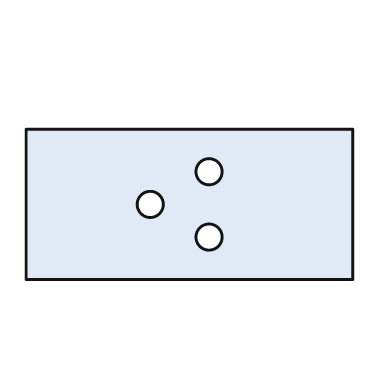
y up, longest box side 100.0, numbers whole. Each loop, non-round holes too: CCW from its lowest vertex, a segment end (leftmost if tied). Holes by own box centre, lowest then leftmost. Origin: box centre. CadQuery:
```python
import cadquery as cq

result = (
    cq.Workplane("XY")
    .moveTo(-50.0, -23.0)
    .lineTo(50.0, -23.0)
    .lineTo(50.0, 23.0)
    .lineTo(-50.0, 23.0)
    .close()
    .moveTo(6.0, -10.0)
    .circle(4.0)
    .moveTo(-12.0, 0.0)
    .circle(4.0)
    .moveTo(6.0, 10.0)
    .circle(4.0)
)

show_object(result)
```